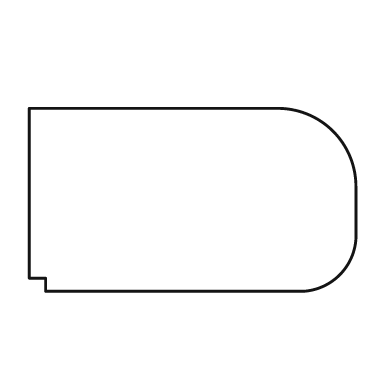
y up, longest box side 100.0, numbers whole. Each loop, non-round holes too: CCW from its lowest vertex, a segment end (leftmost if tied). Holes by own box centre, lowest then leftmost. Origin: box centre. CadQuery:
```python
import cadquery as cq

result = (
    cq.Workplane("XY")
    .moveTo(-45.0, -28.0)
    .lineTo(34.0, -28.0)
    .threePointArc((45.0, -23.0), (50.0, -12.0))
    .lineTo(50.0, 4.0)
    .threePointArc((43.0, 21.0), (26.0, 28.0))
    .lineTo(-50.0, 28.0)
    .lineTo(-50.0, -24.0)
    .lineTo(-45.0, -24.0)
    .close()
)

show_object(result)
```